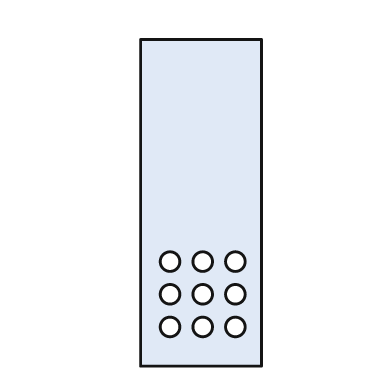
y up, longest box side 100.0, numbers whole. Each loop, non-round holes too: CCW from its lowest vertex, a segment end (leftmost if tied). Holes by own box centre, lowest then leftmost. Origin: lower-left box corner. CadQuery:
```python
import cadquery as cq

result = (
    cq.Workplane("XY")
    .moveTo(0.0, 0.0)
    .lineTo(37.0, 0.0)
    .lineTo(37.0, 100.0)
    .lineTo(0.0, 100.0)
    .close()
    .moveTo(9.0, 12.0)
    .circle(3.0)
    .moveTo(19.0, 12.0)
    .circle(3.0)
    .moveTo(29.0, 12.0)
    .circle(3.0)
    .moveTo(9.0, 22.0)
    .circle(3.0)
    .moveTo(19.0, 22.0)
    .circle(3.0)
    .moveTo(29.0, 22.0)
    .circle(3.0)
    .moveTo(9.0, 32.0)
    .circle(3.0)
    .moveTo(19.0, 32.0)
    .circle(3.0)
    .moveTo(29.0, 32.0)
    .circle(3.0)
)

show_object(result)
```